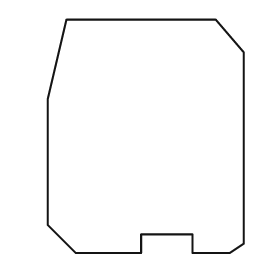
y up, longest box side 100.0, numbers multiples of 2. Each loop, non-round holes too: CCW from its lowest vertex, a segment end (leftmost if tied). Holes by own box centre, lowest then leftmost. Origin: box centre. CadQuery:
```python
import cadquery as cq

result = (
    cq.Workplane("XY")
    .moveTo(-30.0, -50.0)
    .lineTo(-2.0, -50.0)
    .lineTo(-2.0, -42.0)
    .lineTo(20.0, -42.0)
    .lineTo(20.0, -50.0)
    .lineTo(36.0, -50.0)
    .lineTo(42.0, -46.0)
    .lineTo(42.0, 36.0)
    .lineTo(30.0, 50.0)
    .lineTo(-34.0, 50.0)
    .lineTo(-42.0, 16.0)
    .lineTo(-42.0, -38.0)
    .close()
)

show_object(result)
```